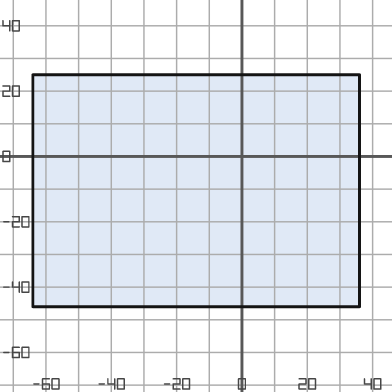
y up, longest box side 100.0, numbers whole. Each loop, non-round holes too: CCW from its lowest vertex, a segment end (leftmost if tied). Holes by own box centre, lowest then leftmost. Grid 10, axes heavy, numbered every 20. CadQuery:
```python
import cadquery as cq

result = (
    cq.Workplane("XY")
    .moveTo(-64.0, -46.0)
    .lineTo(36.0, -46.0)
    .lineTo(36.0, 25.0)
    .lineTo(-64.0, 25.0)
    .close()
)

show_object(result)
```